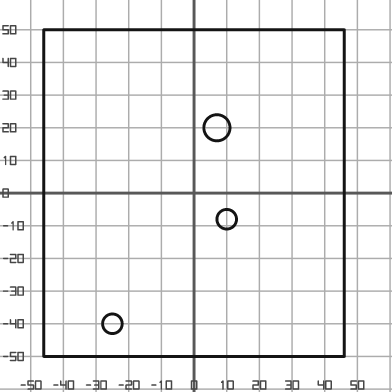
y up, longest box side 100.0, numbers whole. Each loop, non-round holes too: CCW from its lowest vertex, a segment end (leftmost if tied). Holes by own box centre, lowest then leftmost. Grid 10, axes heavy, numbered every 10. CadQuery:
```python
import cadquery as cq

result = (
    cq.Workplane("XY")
    .moveTo(-46.0, -50.0)
    .lineTo(46.0, -50.0)
    .lineTo(46.0, 50.0)
    .lineTo(-46.0, 50.0)
    .close()
    .moveTo(-25.0, -40.0)
    .circle(3.0)
    .moveTo(10.0, -8.0)
    .circle(3.0)
    .moveTo(7.0, 20.0)
    .circle(4.0)
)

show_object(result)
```